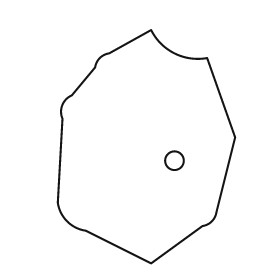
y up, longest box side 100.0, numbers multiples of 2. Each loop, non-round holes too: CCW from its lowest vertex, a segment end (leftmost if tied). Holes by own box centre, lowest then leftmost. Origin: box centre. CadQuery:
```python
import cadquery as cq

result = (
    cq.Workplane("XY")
    .moveTo(2.0, -50.0)
    .lineTo(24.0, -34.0)
    .threePointArc((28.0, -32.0), (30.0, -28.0))
    .lineTo(38.0, 4.0)
    .lineTo(26.0, 38.0)
    .threePointArc((12.0, 40.0), (2.0, 50.0))
    .lineTo(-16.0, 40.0)
    .threePointArc((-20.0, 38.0), (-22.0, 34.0))
    .lineTo(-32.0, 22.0)
    .threePointArc((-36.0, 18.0), (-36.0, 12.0))
    .lineTo(-38.0, -24.0)
    .threePointArc((-34.0, -32.0), (-26.0, -36.0))
    .close()
    .moveTo(12.0, -6.0)
    .circle(4.0)
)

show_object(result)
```